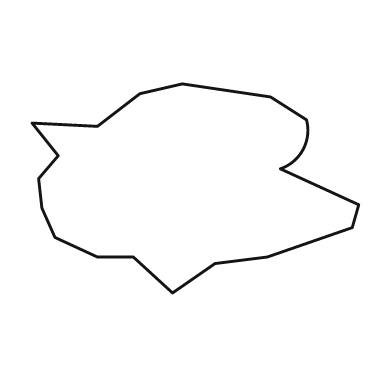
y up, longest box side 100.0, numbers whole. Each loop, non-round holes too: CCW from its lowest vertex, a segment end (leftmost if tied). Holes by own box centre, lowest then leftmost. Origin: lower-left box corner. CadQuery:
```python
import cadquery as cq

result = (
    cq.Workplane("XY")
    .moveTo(43.0, 0.0)
    .lineTo(56.0, 9.0)
    .lineTo(72.0, 11.0)
    .lineTo(98.0, 20.0)
    .lineTo(100.0, 27.0)
    .lineTo(76.0, 38.0)
    .threePointArc((83.0, 44.0), (84.0, 53.0))
    .lineTo(73.0, 60.0)
    .lineTo(46.0, 64.0)
    .lineTo(33.0, 61.0)
    .lineTo(20.0, 51.0)
    .lineTo(0.0, 52.0)
    .lineTo(8.0, 42.0)
    .lineTo(2.0, 35.0)
    .lineTo(3.0, 26.0)
    .lineTo(7.0, 17.0)
    .lineTo(20.0, 11.0)
    .lineTo(31.0, 11.0)
    .close()
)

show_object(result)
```